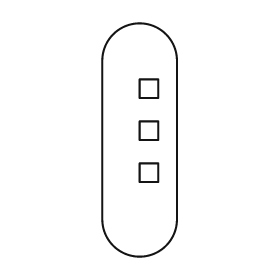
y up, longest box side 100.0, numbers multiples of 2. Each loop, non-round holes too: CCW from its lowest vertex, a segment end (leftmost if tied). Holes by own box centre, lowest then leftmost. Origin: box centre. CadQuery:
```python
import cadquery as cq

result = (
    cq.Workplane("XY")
    .moveTo(-16.0, -34.0)
    .threePointArc((0.0, -50.0), (16.0, -34.0))
    .lineTo(16.0, 34.0)
    .threePointArc((0.0, 50.0), (-16.0, 34.0))
    .close()
    .moveTo(0.0, -18.0)
    .lineTo(8.0, -18.0)
    .lineTo(8.0, -10.0)
    .lineTo(0.0, -10.0)
    .close()
    .moveTo(0.0, 0.0)
    .lineTo(8.0, 0.0)
    .lineTo(8.0, 8.0)
    .lineTo(0.0, 8.0)
    .close()
    .moveTo(0.0, 18.0)
    .lineTo(8.0, 18.0)
    .lineTo(8.0, 26.0)
    .lineTo(0.0, 26.0)
    .close()
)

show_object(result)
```